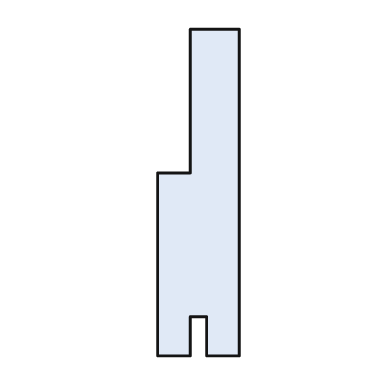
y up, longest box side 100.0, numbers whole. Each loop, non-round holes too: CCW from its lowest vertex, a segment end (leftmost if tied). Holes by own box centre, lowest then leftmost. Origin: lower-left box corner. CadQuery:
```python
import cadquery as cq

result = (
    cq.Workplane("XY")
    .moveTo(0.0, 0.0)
    .lineTo(10.0, 0.0)
    .lineTo(10.0, 12.0)
    .lineTo(15.0, 12.0)
    .lineTo(15.0, 0.0)
    .lineTo(25.0, 0.0)
    .lineTo(25.0, 100.0)
    .lineTo(10.0, 100.0)
    .lineTo(10.0, 56.0)
    .lineTo(0.0, 56.0)
    .close()
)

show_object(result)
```